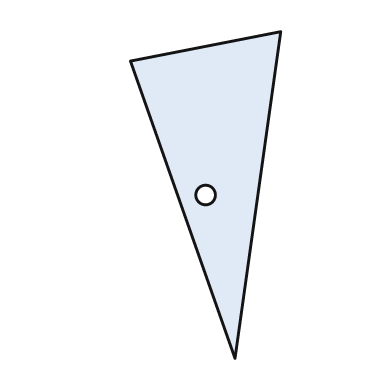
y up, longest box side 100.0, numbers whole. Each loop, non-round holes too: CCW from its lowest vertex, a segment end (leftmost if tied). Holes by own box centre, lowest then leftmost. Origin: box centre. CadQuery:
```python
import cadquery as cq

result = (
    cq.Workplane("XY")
    .moveTo(9.0, -50.0)
    .lineTo(23.0, 50.0)
    .lineTo(-23.0, 41.0)
    .close()
    .moveTo(0.0, 0.0)
    .circle(3.0)
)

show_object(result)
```